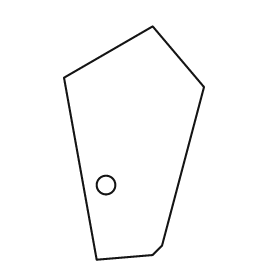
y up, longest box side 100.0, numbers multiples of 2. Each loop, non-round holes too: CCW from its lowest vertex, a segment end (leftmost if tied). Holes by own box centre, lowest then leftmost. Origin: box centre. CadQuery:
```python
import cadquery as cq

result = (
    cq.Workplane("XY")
    .moveTo(-16.0, -50.0)
    .lineTo(8.0, -48.0)
    .lineTo(12.0, -44.0)
    .lineTo(30.0, 24.0)
    .lineTo(8.0, 50.0)
    .lineTo(-30.0, 28.0)
    .close()
    .moveTo(-12.0, -18.0)
    .circle(4.0)
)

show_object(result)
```